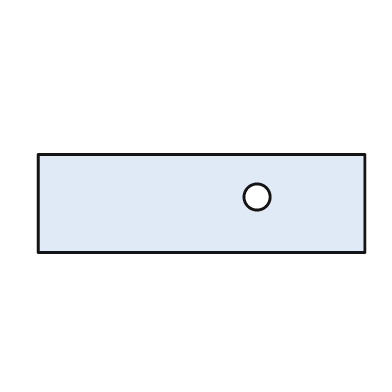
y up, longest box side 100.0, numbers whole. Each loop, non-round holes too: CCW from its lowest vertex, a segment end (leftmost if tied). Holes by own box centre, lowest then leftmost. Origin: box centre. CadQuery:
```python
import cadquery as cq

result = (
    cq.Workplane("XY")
    .moveTo(-50.0, -15.0)
    .lineTo(50.0, -15.0)
    .lineTo(50.0, 15.0)
    .lineTo(-50.0, 15.0)
    .close()
    .moveTo(17.0, 2.0)
    .circle(4.0)
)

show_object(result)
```